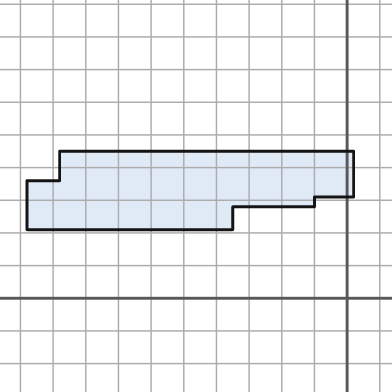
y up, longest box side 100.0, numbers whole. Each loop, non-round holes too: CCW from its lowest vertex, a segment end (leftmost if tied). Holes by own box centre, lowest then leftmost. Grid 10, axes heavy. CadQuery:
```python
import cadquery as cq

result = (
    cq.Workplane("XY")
    .moveTo(-98.0, 21.0)
    .lineTo(-35.0, 21.0)
    .lineTo(-35.0, 28.0)
    .lineTo(-10.0, 28.0)
    .lineTo(-10.0, 31.0)
    .lineTo(2.0, 31.0)
    .lineTo(2.0, 45.0)
    .lineTo(-88.0, 45.0)
    .lineTo(-88.0, 36.0)
    .lineTo(-98.0, 36.0)
    .close()
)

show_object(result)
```